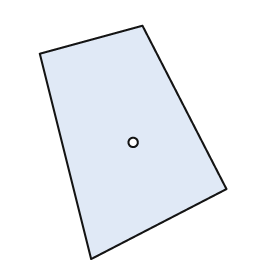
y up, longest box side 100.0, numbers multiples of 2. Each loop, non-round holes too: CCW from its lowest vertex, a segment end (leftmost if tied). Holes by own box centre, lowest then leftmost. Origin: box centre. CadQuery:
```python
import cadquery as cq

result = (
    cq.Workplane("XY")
    .moveTo(-18.0, -50.0)
    .lineTo(40.0, -20.0)
    .lineTo(4.0, 50.0)
    .lineTo(-40.0, 38.0)
    .close()
    .moveTo(0.0, 0.0)
    .circle(2.0)
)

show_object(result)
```